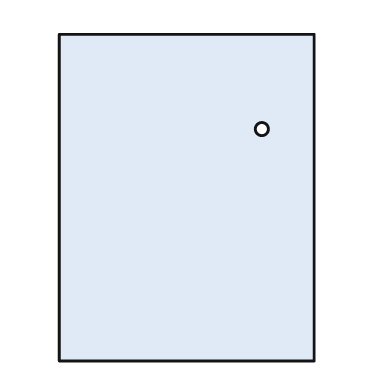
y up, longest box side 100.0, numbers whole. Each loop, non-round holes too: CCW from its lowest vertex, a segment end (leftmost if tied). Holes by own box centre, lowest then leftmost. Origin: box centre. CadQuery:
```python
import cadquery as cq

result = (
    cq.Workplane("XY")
    .moveTo(-39.0, -50.0)
    .lineTo(39.0, -50.0)
    .lineTo(39.0, 50.0)
    .lineTo(-39.0, 50.0)
    .close()
    .moveTo(23.0, 21.0)
    .circle(2.0)
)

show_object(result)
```